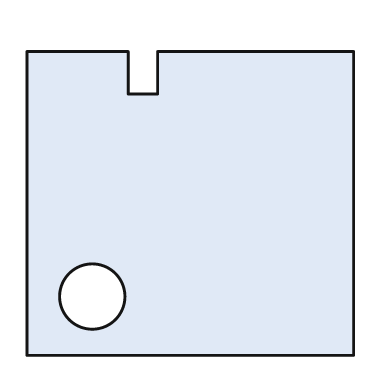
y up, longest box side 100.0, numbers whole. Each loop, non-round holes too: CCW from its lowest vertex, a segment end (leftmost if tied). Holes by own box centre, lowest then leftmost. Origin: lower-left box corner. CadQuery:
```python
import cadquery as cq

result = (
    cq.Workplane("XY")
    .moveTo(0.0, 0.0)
    .lineTo(100.0, 0.0)
    .lineTo(100.0, 93.0)
    .lineTo(40.0, 93.0)
    .lineTo(40.0, 80.0)
    .lineTo(31.0, 80.0)
    .lineTo(31.0, 93.0)
    .lineTo(0.0, 93.0)
    .close()
    .moveTo(20.0, 18.0)
    .circle(10.0)
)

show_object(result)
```